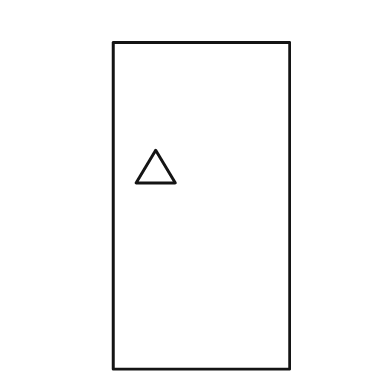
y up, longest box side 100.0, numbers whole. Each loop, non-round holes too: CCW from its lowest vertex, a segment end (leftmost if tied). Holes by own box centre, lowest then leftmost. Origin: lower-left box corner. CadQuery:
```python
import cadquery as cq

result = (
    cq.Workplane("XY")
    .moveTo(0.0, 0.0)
    .lineTo(54.0, 0.0)
    .lineTo(54.0, 100.0)
    .lineTo(0.0, 100.0)
    .close()
    .moveTo(7.0, 57.0)
    .lineTo(19.0, 57.0)
    .lineTo(13.0, 67.0)
    .close()
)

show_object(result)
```